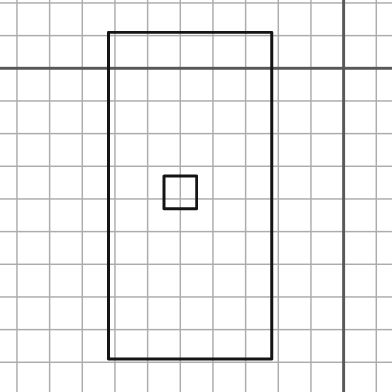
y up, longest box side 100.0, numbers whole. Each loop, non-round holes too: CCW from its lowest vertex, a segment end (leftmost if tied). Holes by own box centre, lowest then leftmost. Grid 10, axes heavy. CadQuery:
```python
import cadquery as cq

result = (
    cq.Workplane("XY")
    .moveTo(-72.0, -89.0)
    .lineTo(-22.0, -89.0)
    .lineTo(-22.0, 11.0)
    .lineTo(-72.0, 11.0)
    .close()
    .moveTo(-55.0, -43.0)
    .lineTo(-45.0, -43.0)
    .lineTo(-45.0, -33.0)
    .lineTo(-55.0, -33.0)
    .close()
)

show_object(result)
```